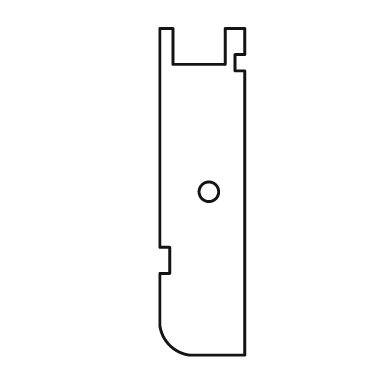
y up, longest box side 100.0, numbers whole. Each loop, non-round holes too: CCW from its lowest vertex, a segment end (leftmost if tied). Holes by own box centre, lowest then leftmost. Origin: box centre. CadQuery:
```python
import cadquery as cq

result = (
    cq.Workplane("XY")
    .moveTo(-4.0, -50.0)
    .lineTo(13.0, -50.0)
    .lineTo(13.0, 37.0)
    .lineTo(10.0, 37.0)
    .lineTo(10.0, 42.0)
    .lineTo(13.0, 42.0)
    .lineTo(13.0, 50.0)
    .lineTo(7.0, 50.0)
    .lineTo(7.0, 39.0)
    .lineTo(-9.0, 39.0)
    .lineTo(-9.0, 50.0)
    .lineTo(-13.0, 50.0)
    .lineTo(-13.0, -17.0)
    .lineTo(-10.0, -17.0)
    .lineTo(-10.0, -25.0)
    .lineTo(-13.0, -25.0)
    .lineTo(-13.0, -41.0)
    .threePointArc((-10.0, -47.0), (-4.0, -50.0))
    .close()
    .moveTo(2.0, 0.0)
    .circle(3.0)
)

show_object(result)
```